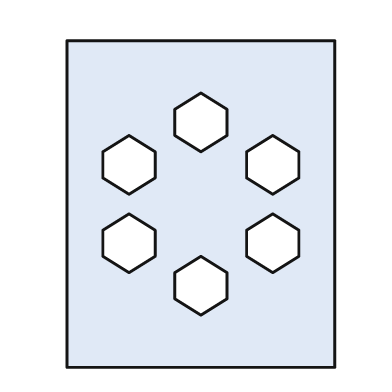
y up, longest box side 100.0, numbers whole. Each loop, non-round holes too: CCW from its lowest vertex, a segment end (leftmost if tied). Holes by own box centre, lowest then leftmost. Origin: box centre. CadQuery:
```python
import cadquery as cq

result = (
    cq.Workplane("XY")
    .moveTo(-41.0, -50.0)
    .lineTo(41.0, -50.0)
    .lineTo(41.0, 50.0)
    .lineTo(-41.0, 50.0)
    .close()
    .moveTo(0.0, -34.0)
    .lineTo(8.0, -29.0)
    .lineTo(8.0, -21.0)
    .lineTo(0.0, -16.0)
    .lineTo(-8.0, -21.0)
    .lineTo(-8.0, -29.0)
    .close()
    .moveTo(-22.0, -21.0)
    .lineTo(-14.0, -16.0)
    .lineTo(-14.0, -8.0)
    .lineTo(-22.0, -3.0)
    .lineTo(-30.0, -8.0)
    .lineTo(-30.0, -16.0)
    .close()
    .moveTo(22.0, -21.0)
    .lineTo(30.0, -16.0)
    .lineTo(30.0, -8.0)
    .lineTo(22.0, -3.0)
    .lineTo(14.0, -8.0)
    .lineTo(14.0, -16.0)
    .close()
    .moveTo(-22.0, 3.0)
    .lineTo(-14.0, 8.0)
    .lineTo(-14.0, 16.0)
    .lineTo(-22.0, 21.0)
    .lineTo(-30.0, 16.0)
    .lineTo(-30.0, 8.0)
    .close()
    .moveTo(22.0, 3.0)
    .lineTo(30.0, 8.0)
    .lineTo(30.0, 16.0)
    .lineTo(22.0, 21.0)
    .lineTo(14.0, 16.0)
    .lineTo(14.0, 8.0)
    .close()
    .moveTo(0.0, 16.0)
    .lineTo(8.0, 21.0)
    .lineTo(8.0, 29.0)
    .lineTo(0.0, 34.0)
    .lineTo(-8.0, 29.0)
    .lineTo(-8.0, 21.0)
    .close()
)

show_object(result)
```